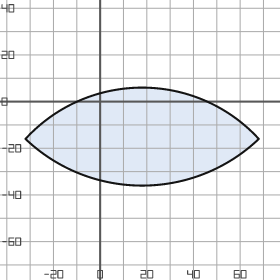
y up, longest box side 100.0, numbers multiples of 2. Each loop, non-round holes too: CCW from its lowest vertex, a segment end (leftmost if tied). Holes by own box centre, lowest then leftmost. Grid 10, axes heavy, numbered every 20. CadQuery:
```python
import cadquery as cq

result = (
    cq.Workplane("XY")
    .moveTo(-32.0, -16.0)
    .threePointArc((18.0, -36.0), (68.0, -16.0))
    .threePointArc((18.0, 6.0), (-32.0, -16.0))
    .close()
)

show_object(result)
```